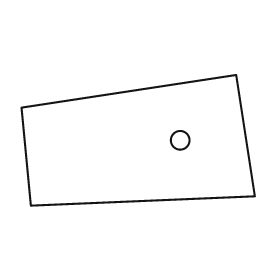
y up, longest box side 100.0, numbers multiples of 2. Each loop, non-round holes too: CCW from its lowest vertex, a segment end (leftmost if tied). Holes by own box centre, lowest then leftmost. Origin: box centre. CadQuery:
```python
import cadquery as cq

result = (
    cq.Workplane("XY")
    .moveTo(-46.0, -28.0)
    .lineTo(50.0, -24.0)
    .lineTo(42.0, 28.0)
    .lineTo(-50.0, 14.0)
    .close()
    .moveTo(18.0, 0.0)
    .circle(4.0)
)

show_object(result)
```